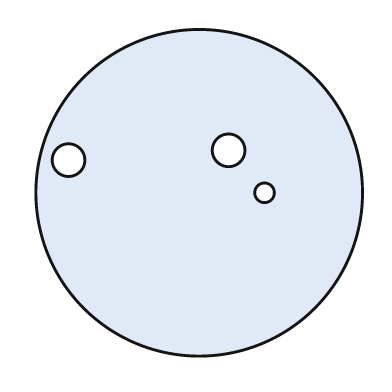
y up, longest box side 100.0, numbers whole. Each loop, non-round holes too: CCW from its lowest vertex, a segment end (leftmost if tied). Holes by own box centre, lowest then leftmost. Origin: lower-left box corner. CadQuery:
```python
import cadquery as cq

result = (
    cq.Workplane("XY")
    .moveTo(50.0, 50.0)
    .circle(50.0)
    .moveTo(70.0, 50.0)
    .circle(3.0)
    .moveTo(10.0, 60.0)
    .circle(5.0)
    .moveTo(59.0, 63.0)
    .circle(5.0)
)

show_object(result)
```